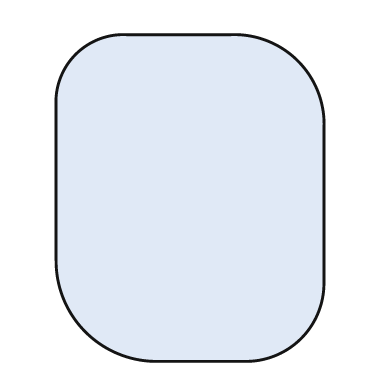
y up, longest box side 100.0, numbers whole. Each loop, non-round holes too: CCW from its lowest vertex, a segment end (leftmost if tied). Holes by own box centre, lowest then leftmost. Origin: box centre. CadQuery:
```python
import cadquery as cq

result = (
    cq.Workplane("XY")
    .moveTo(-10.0, -50.0)
    .lineTo(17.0, -50.0)
    .threePointArc((34.0, -43.0), (41.0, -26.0))
    .lineTo(41.0, 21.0)
    .threePointArc((33.0, 42.0), (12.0, 50.0))
    .lineTo(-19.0, 50.0)
    .threePointArc((-35.0, 44.0), (-41.0, 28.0))
    .lineTo(-41.0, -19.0)
    .threePointArc((-32.0, -41.0), (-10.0, -50.0))
    .close()
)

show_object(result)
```